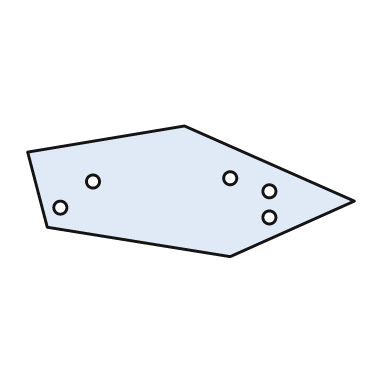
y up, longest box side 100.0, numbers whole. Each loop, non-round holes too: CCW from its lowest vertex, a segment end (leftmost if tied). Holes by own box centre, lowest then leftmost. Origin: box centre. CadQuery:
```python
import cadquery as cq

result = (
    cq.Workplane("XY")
    .moveTo(12.0, -20.0)
    .lineTo(50.0, -3.0)
    .lineTo(-2.0, 20.0)
    .lineTo(-50.0, 12.0)
    .lineTo(-44.0, -11.0)
    .close()
    .moveTo(24.0, -8.0)
    .circle(2.0)
    .moveTo(-40.0, -5.0)
    .circle(2.0)
    .moveTo(24.0, 0.0)
    .circle(2.0)
    .moveTo(-30.0, 3.0)
    .circle(2.0)
    .moveTo(12.0, 4.0)
    .circle(2.0)
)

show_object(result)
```